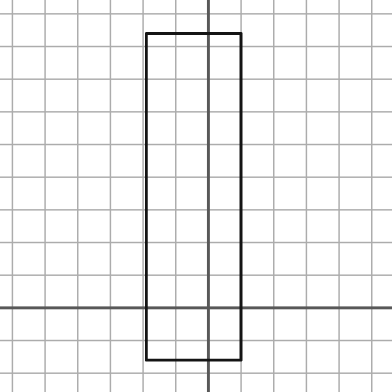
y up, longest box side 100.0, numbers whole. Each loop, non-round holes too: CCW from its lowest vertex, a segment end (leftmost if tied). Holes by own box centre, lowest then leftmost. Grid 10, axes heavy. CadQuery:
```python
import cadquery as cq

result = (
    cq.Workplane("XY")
    .moveTo(-19.0, -16.0)
    .lineTo(10.0, -16.0)
    .lineTo(10.0, 84.0)
    .lineTo(-19.0, 84.0)
    .close()
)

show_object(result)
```